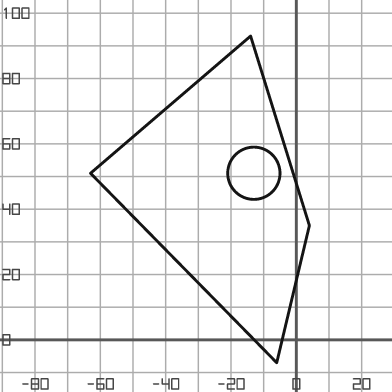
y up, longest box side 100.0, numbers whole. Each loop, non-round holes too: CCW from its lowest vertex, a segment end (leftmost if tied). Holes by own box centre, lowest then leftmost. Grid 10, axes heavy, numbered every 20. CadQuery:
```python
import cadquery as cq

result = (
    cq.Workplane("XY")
    .moveTo(-6.0, -7.0)
    .lineTo(4.0, 35.0)
    .lineTo(-14.0, 93.0)
    .lineTo(-63.0, 51.0)
    .close()
    .moveTo(-13.0, 51.0)
    .circle(8.0)
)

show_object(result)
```